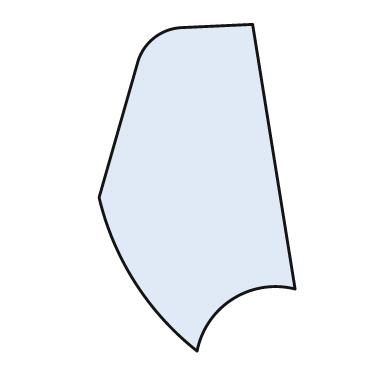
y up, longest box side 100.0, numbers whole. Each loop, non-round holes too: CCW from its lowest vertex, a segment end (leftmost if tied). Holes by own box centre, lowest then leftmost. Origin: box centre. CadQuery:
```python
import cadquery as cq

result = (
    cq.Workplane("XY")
    .moveTo(0.0, -50.0)
    .threePointArc((11.0, -34.0), (30.0, -31.0))
    .lineTo(17.0, 50.0)
    .lineTo(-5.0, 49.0)
    .threePointArc((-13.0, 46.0), (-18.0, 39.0))
    .lineTo(-30.0, -3.0)
    .threePointArc((-19.0, -29.0), (0.0, -50.0))
    .close()
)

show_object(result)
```